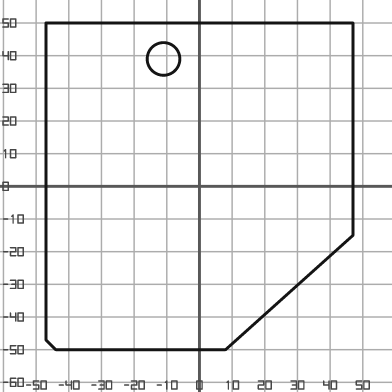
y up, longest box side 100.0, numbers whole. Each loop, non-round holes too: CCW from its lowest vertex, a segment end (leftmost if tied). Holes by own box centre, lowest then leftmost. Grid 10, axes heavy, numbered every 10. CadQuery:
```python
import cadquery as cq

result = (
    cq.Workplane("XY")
    .moveTo(-44.0, -50.0)
    .lineTo(8.0, -50.0)
    .lineTo(47.0, -15.0)
    .lineTo(47.0, 50.0)
    .lineTo(-47.0, 50.0)
    .lineTo(-47.0, -47.0)
    .close()
    .moveTo(-11.0, 39.0)
    .circle(5.0)
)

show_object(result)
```